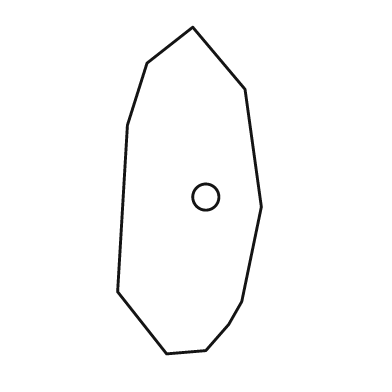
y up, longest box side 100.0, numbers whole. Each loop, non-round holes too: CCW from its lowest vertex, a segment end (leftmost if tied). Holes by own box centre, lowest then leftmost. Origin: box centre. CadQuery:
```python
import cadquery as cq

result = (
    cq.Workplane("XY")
    .moveTo(-7.0, -50.0)
    .lineTo(5.0, -49.0)
    .lineTo(12.0, -41.0)
    .lineTo(16.0, -34.0)
    .lineTo(22.0, -5.0)
    .lineTo(17.0, 31.0)
    .lineTo(1.0, 50.0)
    .lineTo(-13.0, 39.0)
    .lineTo(-19.0, 20.0)
    .lineTo(-22.0, -31.0)
    .close()
    .moveTo(5.0, -2.0)
    .circle(4.0)
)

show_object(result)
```